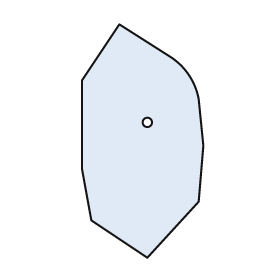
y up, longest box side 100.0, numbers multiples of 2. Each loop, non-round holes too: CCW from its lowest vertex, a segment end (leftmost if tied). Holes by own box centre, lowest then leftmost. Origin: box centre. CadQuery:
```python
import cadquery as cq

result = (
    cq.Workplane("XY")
    .moveTo(2.0, -50.0)
    .lineTo(24.0, -26.0)
    .lineTo(26.0, -2.0)
    .lineTo(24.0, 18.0)
    .threePointArc((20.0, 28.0), (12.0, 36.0))
    .lineTo(-10.0, 50.0)
    .lineTo(-26.0, 26.0)
    .lineTo(-26.0, -12.0)
    .lineTo(-22.0, -34.0)
    .close()
    .moveTo(2.0, 8.0)
    .circle(2.0)
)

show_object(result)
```